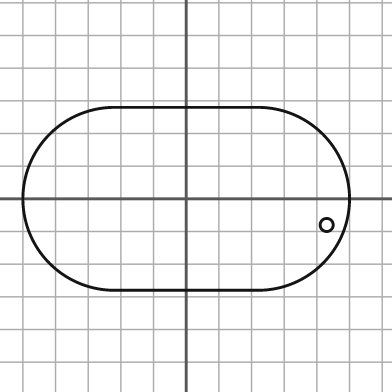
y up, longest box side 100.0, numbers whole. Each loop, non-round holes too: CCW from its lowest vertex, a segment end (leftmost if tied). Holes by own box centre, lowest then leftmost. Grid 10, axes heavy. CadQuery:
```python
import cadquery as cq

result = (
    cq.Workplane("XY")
    .moveTo(-22.0, -28.0)
    .lineTo(22.0, -28.0)
    .threePointArc((50.0, 0.0), (22.0, 28.0))
    .lineTo(-22.0, 28.0)
    .threePointArc((-50.0, 0.0), (-22.0, -28.0))
    .close()
    .moveTo(43.0, -8.0)
    .circle(2.0)
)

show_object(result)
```